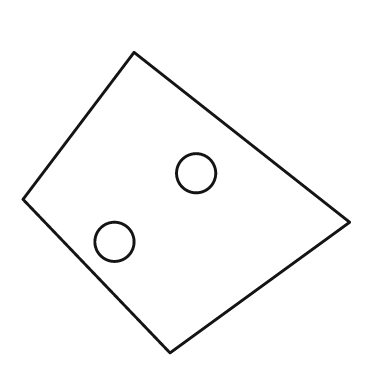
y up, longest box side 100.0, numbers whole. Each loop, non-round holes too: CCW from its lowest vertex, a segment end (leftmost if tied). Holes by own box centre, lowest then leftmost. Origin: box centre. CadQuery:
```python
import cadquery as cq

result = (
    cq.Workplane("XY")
    .moveTo(-5.0, -46.0)
    .lineTo(50.0, -6.0)
    .lineTo(-16.0, 46.0)
    .lineTo(-50.0, 1.0)
    .close()
    .moveTo(-22.0, -12.0)
    .circle(6.0)
    .moveTo(3.0, 9.0)
    .circle(6.0)
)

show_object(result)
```